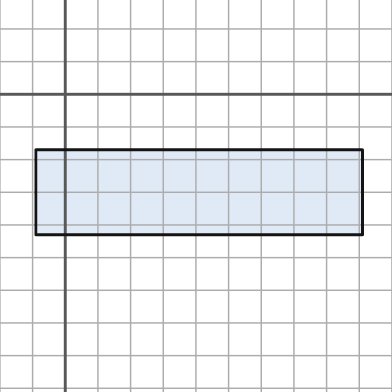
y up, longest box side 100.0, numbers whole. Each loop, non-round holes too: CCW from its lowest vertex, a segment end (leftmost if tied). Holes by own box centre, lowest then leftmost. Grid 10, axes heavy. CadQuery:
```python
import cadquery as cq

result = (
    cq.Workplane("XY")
    .moveTo(-9.0, -43.0)
    .lineTo(91.0, -43.0)
    .lineTo(91.0, -17.0)
    .lineTo(-9.0, -17.0)
    .close()
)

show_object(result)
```